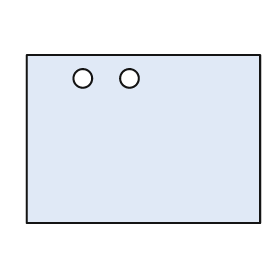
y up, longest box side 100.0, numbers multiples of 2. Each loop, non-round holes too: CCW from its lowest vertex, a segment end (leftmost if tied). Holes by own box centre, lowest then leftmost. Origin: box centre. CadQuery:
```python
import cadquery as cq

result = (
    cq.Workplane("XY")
    .moveTo(-50.0, -36.0)
    .lineTo(50.0, -36.0)
    .lineTo(50.0, 36.0)
    .lineTo(-50.0, 36.0)
    .close()
    .moveTo(-26.0, 26.0)
    .circle(4.0)
    .moveTo(-6.0, 26.0)
    .circle(4.0)
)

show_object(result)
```